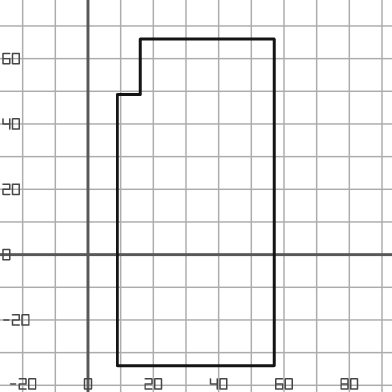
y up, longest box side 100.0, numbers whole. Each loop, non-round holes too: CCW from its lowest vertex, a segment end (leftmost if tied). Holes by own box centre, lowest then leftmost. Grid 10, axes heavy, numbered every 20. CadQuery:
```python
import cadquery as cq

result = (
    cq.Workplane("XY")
    .moveTo(9.0, -34.0)
    .lineTo(57.0, -34.0)
    .lineTo(57.0, 66.0)
    .lineTo(16.0, 66.0)
    .lineTo(16.0, 49.0)
    .lineTo(9.0, 49.0)
    .close()
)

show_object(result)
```